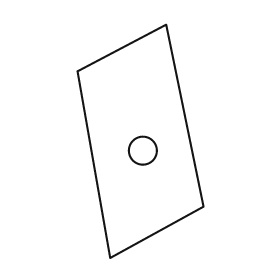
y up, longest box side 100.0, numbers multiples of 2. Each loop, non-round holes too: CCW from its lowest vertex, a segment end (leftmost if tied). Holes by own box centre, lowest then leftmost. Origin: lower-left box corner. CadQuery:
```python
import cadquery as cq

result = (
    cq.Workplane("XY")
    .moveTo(14.0, 0.0)
    .lineTo(54.0, 22.0)
    .lineTo(38.0, 100.0)
    .lineTo(0.0, 80.0)
    .close()
    .moveTo(28.0, 46.0)
    .circle(6.0)
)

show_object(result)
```